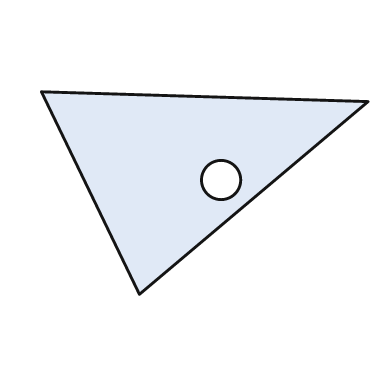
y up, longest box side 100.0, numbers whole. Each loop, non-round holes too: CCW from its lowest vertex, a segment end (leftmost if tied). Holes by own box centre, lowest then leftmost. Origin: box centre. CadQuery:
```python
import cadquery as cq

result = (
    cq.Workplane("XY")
    .moveTo(-20.0, -31.0)
    .lineTo(50.0, 28.0)
    .lineTo(-50.0, 31.0)
    .close()
    .moveTo(5.0, 4.0)
    .circle(6.0)
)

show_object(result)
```